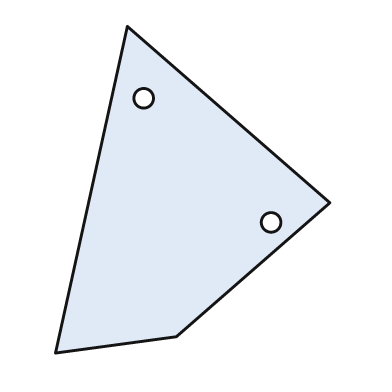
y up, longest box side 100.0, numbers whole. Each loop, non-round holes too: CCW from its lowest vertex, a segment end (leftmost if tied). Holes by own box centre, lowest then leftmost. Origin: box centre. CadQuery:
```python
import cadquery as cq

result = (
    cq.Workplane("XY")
    .moveTo(-42.0, -50.0)
    .lineTo(-5.0, -45.0)
    .lineTo(42.0, -4.0)
    .lineTo(-20.0, 50.0)
    .close()
    .moveTo(24.0, -10.0)
    .circle(3.0)
    .moveTo(-15.0, 28.0)
    .circle(3.0)
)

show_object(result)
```